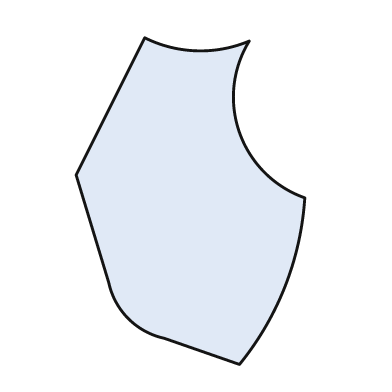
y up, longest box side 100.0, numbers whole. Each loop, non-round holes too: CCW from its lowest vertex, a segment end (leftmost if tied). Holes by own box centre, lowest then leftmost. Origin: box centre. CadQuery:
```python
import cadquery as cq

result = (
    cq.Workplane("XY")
    .moveTo(15.0, -50.0)
    .threePointArc((29.0, -26.0), (35.0, 1.0))
    .threePointArc((15.0, 21.0), (18.0, 49.0))
    .threePointArc((2.0, 46.0), (-14.0, 50.0))
    .lineTo(-35.0, 8.0)
    .lineTo(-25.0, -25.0)
    .threePointArc((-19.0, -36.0), (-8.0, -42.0))
    .close()
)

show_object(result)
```